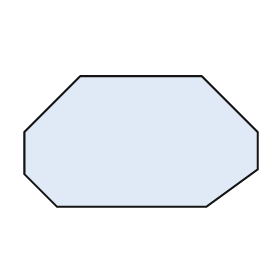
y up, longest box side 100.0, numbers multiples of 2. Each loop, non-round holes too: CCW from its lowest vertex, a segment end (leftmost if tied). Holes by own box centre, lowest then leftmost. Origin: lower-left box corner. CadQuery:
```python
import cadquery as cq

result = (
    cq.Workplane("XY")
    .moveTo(14.0, 0.0)
    .lineTo(78.0, 0.0)
    .lineTo(100.0, 16.0)
    .lineTo(100.0, 32.0)
    .lineTo(76.0, 56.0)
    .lineTo(24.0, 56.0)
    .lineTo(0.0, 32.0)
    .lineTo(0.0, 14.0)
    .close()
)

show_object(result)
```